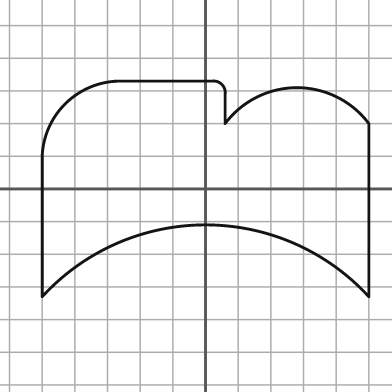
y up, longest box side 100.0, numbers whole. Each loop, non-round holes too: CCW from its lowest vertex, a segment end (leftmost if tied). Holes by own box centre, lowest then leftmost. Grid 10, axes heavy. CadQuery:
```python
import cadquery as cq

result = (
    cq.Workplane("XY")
    .moveTo(-50.0, -33.0)
    .threePointArc((0.0, -11.0), (50.0, -33.0))
    .lineTo(50.0, 20.0)
    .threePointArc((28.0, 31.0), (6.0, 20.0))
    .lineTo(6.0, 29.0)
    .threePointArc((5.0, 32.0), (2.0, 33.0))
    .lineTo(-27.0, 33.0)
    .threePointArc((-43.0, 26.0), (-50.0, 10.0))
    .close()
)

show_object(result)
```